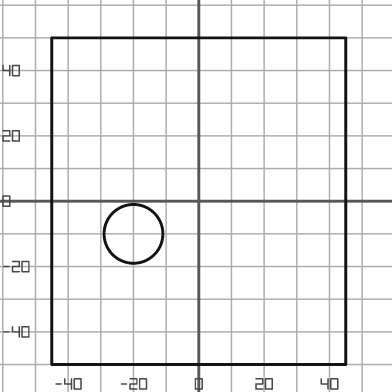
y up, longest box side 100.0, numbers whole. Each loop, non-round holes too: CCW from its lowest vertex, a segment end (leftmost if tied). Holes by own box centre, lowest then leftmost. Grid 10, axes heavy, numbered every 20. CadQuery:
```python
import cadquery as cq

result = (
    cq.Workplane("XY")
    .moveTo(-45.0, -50.0)
    .lineTo(45.0, -50.0)
    .lineTo(45.0, 50.0)
    .lineTo(-45.0, 50.0)
    .close()
    .moveTo(-20.0, -10.0)
    .circle(9.0)
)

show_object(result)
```